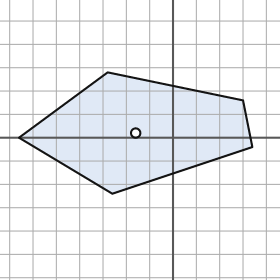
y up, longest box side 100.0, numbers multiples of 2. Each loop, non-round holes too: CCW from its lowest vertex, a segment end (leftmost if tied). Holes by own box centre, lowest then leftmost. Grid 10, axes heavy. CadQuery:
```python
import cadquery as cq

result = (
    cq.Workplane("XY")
    .moveTo(-26.0, -24.0)
    .lineTo(34.0, -4.0)
    .lineTo(30.0, 16.0)
    .lineTo(-28.0, 28.0)
    .lineTo(-66.0, 0.0)
    .close()
    .moveTo(-16.0, 2.0)
    .circle(2.0)
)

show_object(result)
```